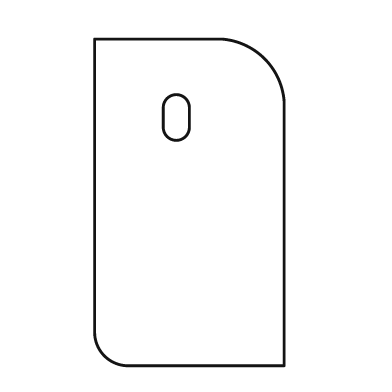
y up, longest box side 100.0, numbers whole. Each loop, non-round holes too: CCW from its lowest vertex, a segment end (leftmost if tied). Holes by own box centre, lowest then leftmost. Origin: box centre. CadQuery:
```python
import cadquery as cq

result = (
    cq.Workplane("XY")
    .moveTo(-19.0, -50.0)
    .lineTo(29.0, -50.0)
    .lineTo(29.0, 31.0)
    .threePointArc((23.0, 44.0), (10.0, 50.0))
    .lineTo(-29.0, 50.0)
    .lineTo(-29.0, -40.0)
    .threePointArc((-26.0, -47.0), (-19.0, -50.0))
    .close()
    .moveTo(-8.0, 23.0)
    .threePointArc((-4.0, 19.0), (0.0, 23.0))
    .lineTo(0.0, 29.0)
    .threePointArc((-4.0, 33.0), (-8.0, 29.0))
    .close()
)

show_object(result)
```